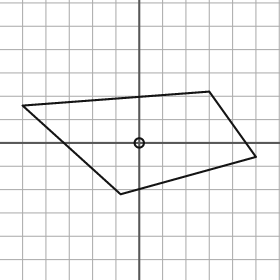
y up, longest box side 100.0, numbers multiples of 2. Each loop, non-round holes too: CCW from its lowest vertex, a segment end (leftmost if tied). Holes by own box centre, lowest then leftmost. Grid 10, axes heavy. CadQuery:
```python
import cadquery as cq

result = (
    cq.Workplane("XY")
    .moveTo(-8.0, -22.0)
    .lineTo(50.0, -6.0)
    .lineTo(30.0, 22.0)
    .lineTo(-50.0, 16.0)
    .close()
    .moveTo(0.0, 0.0)
    .circle(2.0)
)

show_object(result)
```